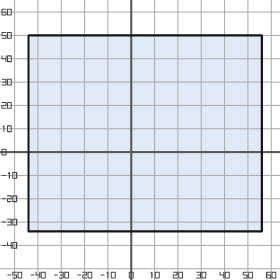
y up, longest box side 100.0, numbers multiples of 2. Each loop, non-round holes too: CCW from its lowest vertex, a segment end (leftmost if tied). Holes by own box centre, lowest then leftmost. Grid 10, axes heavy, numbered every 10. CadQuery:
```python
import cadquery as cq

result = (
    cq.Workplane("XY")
    .moveTo(-44.0, -34.0)
    .lineTo(56.0, -34.0)
    .lineTo(56.0, 50.0)
    .lineTo(-44.0, 50.0)
    .close()
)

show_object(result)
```